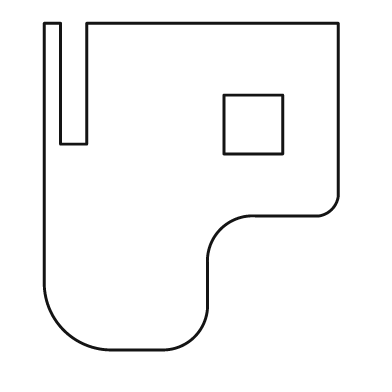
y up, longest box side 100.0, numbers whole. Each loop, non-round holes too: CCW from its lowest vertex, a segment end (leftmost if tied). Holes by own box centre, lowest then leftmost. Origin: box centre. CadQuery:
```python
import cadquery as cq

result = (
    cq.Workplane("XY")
    .moveTo(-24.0, -50.0)
    .lineTo(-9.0, -50.0)
    .threePointArc((1.0, -46.0), (5.0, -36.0))
    .lineTo(5.0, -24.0)
    .threePointArc((9.0, -13.0), (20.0, -9.0))
    .lineTo(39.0, -9.0)
    .threePointArc((43.0, -7.0), (45.0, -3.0))
    .lineTo(45.0, 50.0)
    .lineTo(-32.0, 50.0)
    .lineTo(-32.0, 13.0)
    .lineTo(-40.0, 13.0)
    .lineTo(-40.0, 50.0)
    .lineTo(-45.0, 50.0)
    .lineTo(-45.0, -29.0)
    .threePointArc((-39.0, -44.0), (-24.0, -50.0))
    .close()
    .moveTo(10.0, 10.0)
    .lineTo(28.0, 10.0)
    .lineTo(28.0, 28.0)
    .lineTo(10.0, 28.0)
    .close()
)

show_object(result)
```